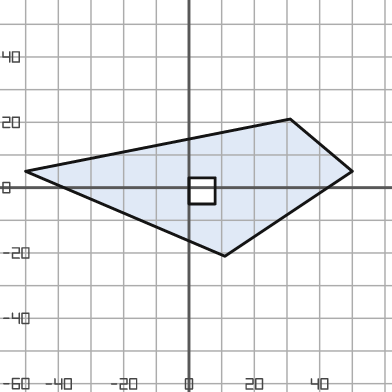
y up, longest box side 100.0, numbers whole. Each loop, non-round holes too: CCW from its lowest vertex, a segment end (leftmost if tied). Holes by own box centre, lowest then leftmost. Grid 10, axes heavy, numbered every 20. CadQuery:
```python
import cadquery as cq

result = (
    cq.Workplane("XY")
    .moveTo(11.0, -21.0)
    .lineTo(50.0, 5.0)
    .lineTo(31.0, 21.0)
    .lineTo(-50.0, 5.0)
    .close()
    .moveTo(0.0, -5.0)
    .lineTo(8.0, -5.0)
    .lineTo(8.0, 3.0)
    .lineTo(0.0, 3.0)
    .close()
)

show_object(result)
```